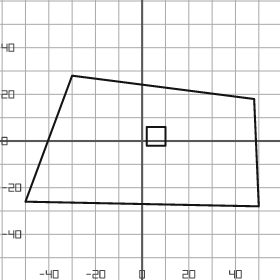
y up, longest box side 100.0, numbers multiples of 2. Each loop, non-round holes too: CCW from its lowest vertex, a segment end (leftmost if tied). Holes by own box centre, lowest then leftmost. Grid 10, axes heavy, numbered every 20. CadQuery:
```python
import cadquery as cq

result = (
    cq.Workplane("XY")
    .moveTo(50.0, -28.0)
    .lineTo(48.0, 18.0)
    .lineTo(-30.0, 28.0)
    .lineTo(-50.0, -26.0)
    .close()
    .moveTo(2.0, -2.0)
    .lineTo(10.0, -2.0)
    .lineTo(10.0, 6.0)
    .lineTo(2.0, 6.0)
    .close()
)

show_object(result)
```